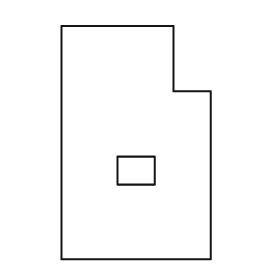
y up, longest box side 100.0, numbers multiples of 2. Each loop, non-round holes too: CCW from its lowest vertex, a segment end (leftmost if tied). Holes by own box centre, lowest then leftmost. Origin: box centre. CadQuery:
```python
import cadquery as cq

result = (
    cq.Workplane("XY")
    .moveTo(-32.0, -50.0)
    .lineTo(32.0, -50.0)
    .lineTo(32.0, 22.0)
    .lineTo(16.0, 22.0)
    .lineTo(16.0, 50.0)
    .lineTo(-32.0, 50.0)
    .close()
    .moveTo(-8.0, -18.0)
    .lineTo(8.0, -18.0)
    .lineTo(8.0, -6.0)
    .lineTo(-8.0, -6.0)
    .close()
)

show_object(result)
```